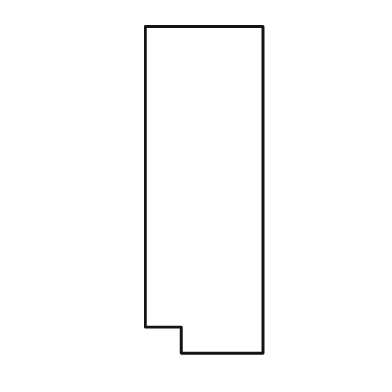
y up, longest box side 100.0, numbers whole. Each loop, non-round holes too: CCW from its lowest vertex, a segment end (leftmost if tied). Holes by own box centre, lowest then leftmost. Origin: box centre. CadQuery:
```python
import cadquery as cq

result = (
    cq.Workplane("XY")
    .moveTo(-7.0, -50.0)
    .lineTo(18.0, -50.0)
    .lineTo(18.0, 50.0)
    .lineTo(-18.0, 50.0)
    .lineTo(-18.0, -42.0)
    .lineTo(-7.0, -42.0)
    .close()
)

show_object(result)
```